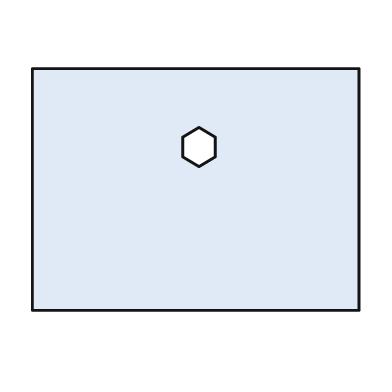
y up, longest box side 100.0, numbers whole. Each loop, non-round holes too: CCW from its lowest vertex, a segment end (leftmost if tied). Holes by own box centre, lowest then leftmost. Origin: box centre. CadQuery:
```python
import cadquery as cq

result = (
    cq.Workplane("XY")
    .moveTo(-50.0, -37.0)
    .lineTo(50.0, -37.0)
    .lineTo(50.0, 37.0)
    .lineTo(-50.0, 37.0)
    .close()
    .moveTo(1.0, 7.0)
    .lineTo(6.0, 10.0)
    .lineTo(6.0, 16.0)
    .lineTo(1.0, 19.0)
    .lineTo(-4.0, 16.0)
    .lineTo(-4.0, 10.0)
    .close()
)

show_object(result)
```